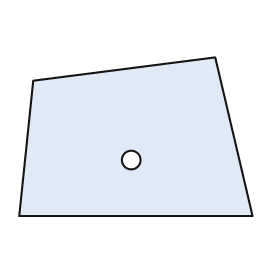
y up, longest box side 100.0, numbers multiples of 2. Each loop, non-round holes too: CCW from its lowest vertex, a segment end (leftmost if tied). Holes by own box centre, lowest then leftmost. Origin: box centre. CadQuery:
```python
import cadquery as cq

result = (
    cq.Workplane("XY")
    .moveTo(-50.0, -34.0)
    .lineTo(50.0, -34.0)
    .lineTo(34.0, 34.0)
    .lineTo(-44.0, 24.0)
    .close()
    .moveTo(-2.0, -10.0)
    .circle(4.0)
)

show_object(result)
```